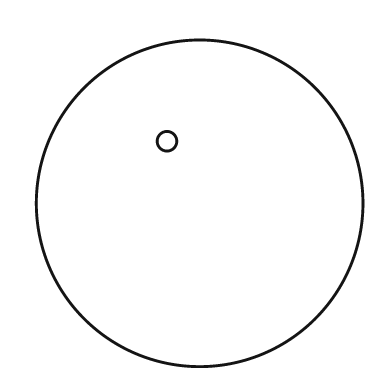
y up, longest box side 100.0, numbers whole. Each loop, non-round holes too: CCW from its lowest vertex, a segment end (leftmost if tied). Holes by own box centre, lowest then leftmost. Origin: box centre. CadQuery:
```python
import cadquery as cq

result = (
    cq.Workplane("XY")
    .moveTo(0.0, 0.0)
    .circle(50.0)
    .moveTo(-10.0, 19.0)
    .circle(3.0)
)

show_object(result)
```